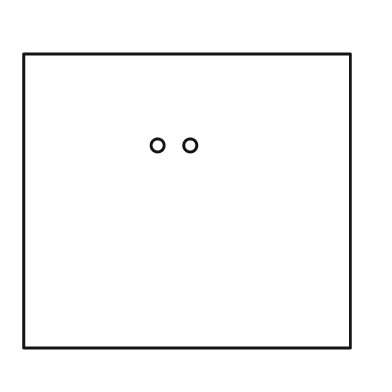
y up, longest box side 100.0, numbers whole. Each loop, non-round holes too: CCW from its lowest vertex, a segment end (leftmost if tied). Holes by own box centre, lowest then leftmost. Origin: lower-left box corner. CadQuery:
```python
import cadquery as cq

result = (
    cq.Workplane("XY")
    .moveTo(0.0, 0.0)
    .lineTo(100.0, 0.0)
    .lineTo(100.0, 90.0)
    .lineTo(0.0, 90.0)
    .close()
    .moveTo(41.0, 62.0)
    .circle(2.0)
    .moveTo(51.0, 62.0)
    .circle(2.0)
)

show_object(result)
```